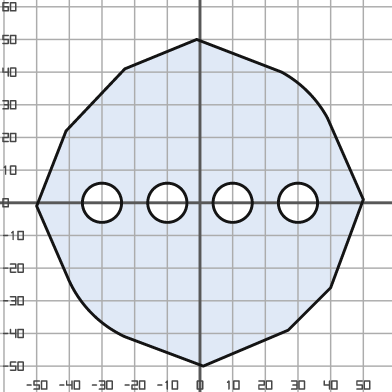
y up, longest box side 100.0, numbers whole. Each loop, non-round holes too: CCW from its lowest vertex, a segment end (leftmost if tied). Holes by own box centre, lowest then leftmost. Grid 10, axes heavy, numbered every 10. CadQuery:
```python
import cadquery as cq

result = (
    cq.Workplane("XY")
    .moveTo(1.0, -50.0)
    .lineTo(27.0, -39.0)
    .lineTo(40.0, -26.0)
    .lineTo(50.0, 1.0)
    .lineTo(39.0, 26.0)
    .threePointArc((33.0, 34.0), (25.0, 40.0))
    .lineTo(-1.0, 50.0)
    .lineTo(-23.0, 41.0)
    .lineTo(-41.0, 22.0)
    .lineTo(-50.0, -1.0)
    .lineTo(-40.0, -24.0)
    .threePointArc((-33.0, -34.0), (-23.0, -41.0))
    .close()
    .moveTo(-30.0, 0.0)
    .circle(6.0)
    .moveTo(-10.0, 0.0)
    .circle(6.0)
    .moveTo(10.0, 0.0)
    .circle(6.0)
    .moveTo(30.0, 0.0)
    .circle(6.0)
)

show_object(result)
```